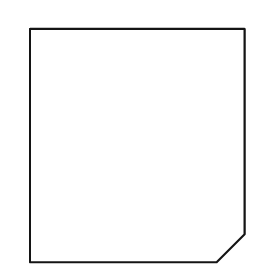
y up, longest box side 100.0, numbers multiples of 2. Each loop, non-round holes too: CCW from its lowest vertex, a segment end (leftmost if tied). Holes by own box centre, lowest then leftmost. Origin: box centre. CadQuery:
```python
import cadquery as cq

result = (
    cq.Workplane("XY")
    .moveTo(-46.0, -50.0)
    .lineTo(34.0, -50.0)
    .lineTo(46.0, -38.0)
    .lineTo(46.0, 50.0)
    .lineTo(-46.0, 50.0)
    .close()
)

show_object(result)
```